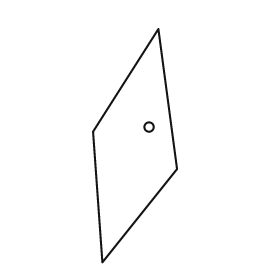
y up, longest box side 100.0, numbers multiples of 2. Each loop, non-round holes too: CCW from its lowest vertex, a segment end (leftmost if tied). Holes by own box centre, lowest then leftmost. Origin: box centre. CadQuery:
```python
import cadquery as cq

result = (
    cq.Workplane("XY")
    .moveTo(-14.0, -50.0)
    .lineTo(18.0, -10.0)
    .lineTo(10.0, 50.0)
    .lineTo(-18.0, 6.0)
    .close()
    .moveTo(6.0, 8.0)
    .circle(2.0)
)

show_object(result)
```